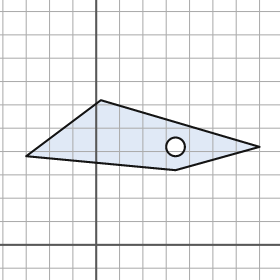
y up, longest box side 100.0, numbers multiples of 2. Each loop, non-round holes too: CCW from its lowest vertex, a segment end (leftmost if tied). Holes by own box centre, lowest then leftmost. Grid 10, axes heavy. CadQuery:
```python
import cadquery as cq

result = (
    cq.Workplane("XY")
    .moveTo(34.0, 32.0)
    .lineTo(70.0, 42.0)
    .lineTo(2.0, 62.0)
    .lineTo(-30.0, 38.0)
    .close()
    .moveTo(34.0, 42.0)
    .circle(4.0)
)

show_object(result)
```